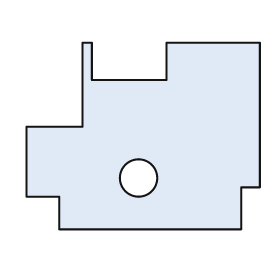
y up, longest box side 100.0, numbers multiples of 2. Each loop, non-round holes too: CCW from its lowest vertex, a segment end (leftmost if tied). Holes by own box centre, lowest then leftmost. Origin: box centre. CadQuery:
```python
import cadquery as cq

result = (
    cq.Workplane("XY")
    .moveTo(-36.0, -40.0)
    .lineTo(42.0, -40.0)
    .lineTo(42.0, -22.0)
    .lineTo(50.0, -22.0)
    .lineTo(50.0, 40.0)
    .lineTo(10.0, 40.0)
    .lineTo(10.0, 24.0)
    .lineTo(-22.0, 24.0)
    .lineTo(-22.0, 40.0)
    .lineTo(-26.0, 40.0)
    .lineTo(-26.0, 4.0)
    .lineTo(-50.0, 4.0)
    .lineTo(-50.0, -26.0)
    .lineTo(-36.0, -26.0)
    .close()
    .moveTo(-2.0, -18.0)
    .circle(8.0)
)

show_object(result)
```